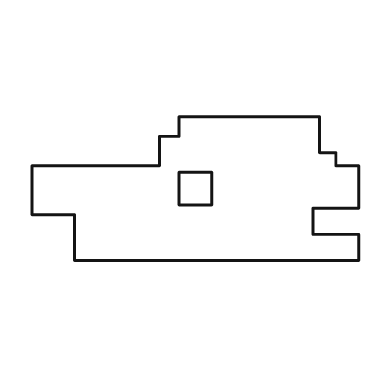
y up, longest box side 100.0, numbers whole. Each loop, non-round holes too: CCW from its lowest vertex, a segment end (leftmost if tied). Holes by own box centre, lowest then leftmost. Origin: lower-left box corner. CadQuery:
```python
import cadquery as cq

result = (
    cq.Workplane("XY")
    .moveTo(13.0, 0.0)
    .lineTo(100.0, 0.0)
    .lineTo(100.0, 8.0)
    .lineTo(86.0, 8.0)
    .lineTo(86.0, 16.0)
    .lineTo(100.0, 16.0)
    .lineTo(100.0, 29.0)
    .lineTo(93.0, 29.0)
    .lineTo(93.0, 33.0)
    .lineTo(88.0, 33.0)
    .lineTo(88.0, 44.0)
    .lineTo(45.0, 44.0)
    .lineTo(45.0, 38.0)
    .lineTo(39.0, 38.0)
    .lineTo(39.0, 29.0)
    .lineTo(0.0, 29.0)
    .lineTo(0.0, 14.0)
    .lineTo(13.0, 14.0)
    .close()
    .moveTo(45.0, 17.0)
    .lineTo(55.0, 17.0)
    .lineTo(55.0, 27.0)
    .lineTo(45.0, 27.0)
    .close()
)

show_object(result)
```